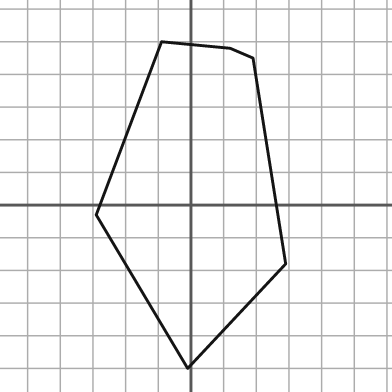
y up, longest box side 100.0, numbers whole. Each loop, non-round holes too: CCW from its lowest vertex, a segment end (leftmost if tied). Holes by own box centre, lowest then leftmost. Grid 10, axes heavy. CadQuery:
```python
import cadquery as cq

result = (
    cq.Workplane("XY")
    .moveTo(-1.0, -50.0)
    .lineTo(29.0, -18.0)
    .lineTo(19.0, 45.0)
    .lineTo(12.0, 48.0)
    .lineTo(-9.0, 50.0)
    .lineTo(-29.0, -3.0)
    .close()
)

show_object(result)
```